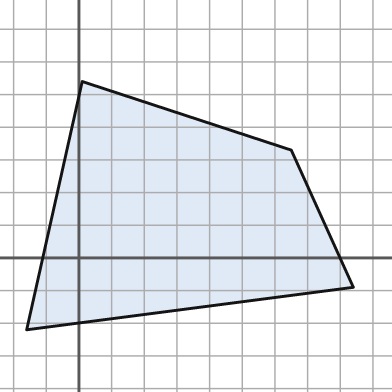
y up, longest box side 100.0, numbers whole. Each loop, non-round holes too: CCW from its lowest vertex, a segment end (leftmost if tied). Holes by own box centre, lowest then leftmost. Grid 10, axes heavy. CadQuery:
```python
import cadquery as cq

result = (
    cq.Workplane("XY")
    .moveTo(-16.0, -22.0)
    .lineTo(84.0, -9.0)
    .lineTo(65.0, 33.0)
    .lineTo(1.0, 54.0)
    .close()
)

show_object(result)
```